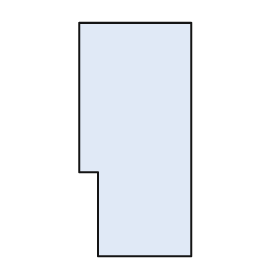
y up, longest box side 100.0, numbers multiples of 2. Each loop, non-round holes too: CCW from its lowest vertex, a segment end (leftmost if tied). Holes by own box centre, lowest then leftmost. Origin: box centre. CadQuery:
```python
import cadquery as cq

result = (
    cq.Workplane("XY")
    .moveTo(-16.0, -50.0)
    .lineTo(24.0, -50.0)
    .lineTo(24.0, 50.0)
    .lineTo(-24.0, 50.0)
    .lineTo(-24.0, -14.0)
    .lineTo(-16.0, -14.0)
    .close()
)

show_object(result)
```